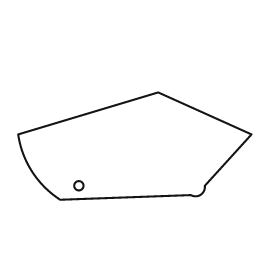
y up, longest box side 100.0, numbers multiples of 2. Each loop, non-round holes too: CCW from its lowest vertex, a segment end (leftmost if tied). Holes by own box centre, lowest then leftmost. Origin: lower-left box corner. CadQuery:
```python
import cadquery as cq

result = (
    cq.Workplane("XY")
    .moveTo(18.0, 0.0)
    .lineTo(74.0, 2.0)
    .threePointArc((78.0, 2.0), (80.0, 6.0))
    .lineTo(100.0, 28.0)
    .lineTo(60.0, 46.0)
    .lineTo(0.0, 28.0)
    .threePointArc((6.0, 12.0), (18.0, 0.0))
    .close()
    .moveTo(26.0, 6.0)
    .circle(2.0)
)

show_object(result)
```